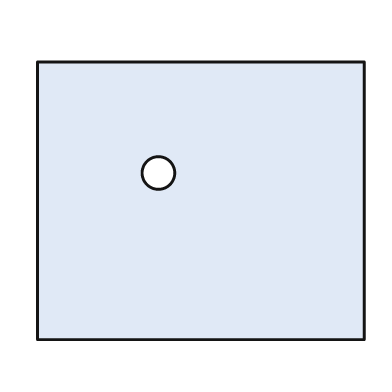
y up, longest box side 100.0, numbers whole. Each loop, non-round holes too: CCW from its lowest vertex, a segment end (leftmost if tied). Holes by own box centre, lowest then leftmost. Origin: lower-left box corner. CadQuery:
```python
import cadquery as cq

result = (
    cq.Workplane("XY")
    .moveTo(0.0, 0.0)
    .lineTo(100.0, 0.0)
    .lineTo(100.0, 85.0)
    .lineTo(0.0, 85.0)
    .close()
    .moveTo(37.0, 51.0)
    .circle(5.0)
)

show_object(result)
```